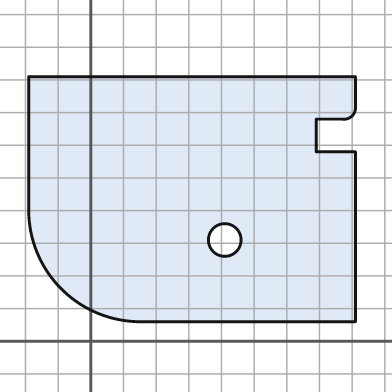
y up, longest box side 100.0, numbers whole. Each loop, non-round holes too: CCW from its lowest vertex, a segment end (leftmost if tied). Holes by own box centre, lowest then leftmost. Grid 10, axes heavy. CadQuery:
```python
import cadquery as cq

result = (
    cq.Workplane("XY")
    .moveTo(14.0, 6.0)
    .lineTo(81.0, 6.0)
    .lineTo(81.0, 58.0)
    .lineTo(69.0, 58.0)
    .lineTo(69.0, 68.0)
    .lineTo(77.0, 68.0)
    .threePointArc((80.0, 69.0), (81.0, 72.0))
    .lineTo(81.0, 81.0)
    .lineTo(-19.0, 81.0)
    .lineTo(-19.0, 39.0)
    .threePointArc((-9.0, 16.0), (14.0, 6.0))
    .close()
    .moveTo(41.0, 31.0)
    .circle(5.0)
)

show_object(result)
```